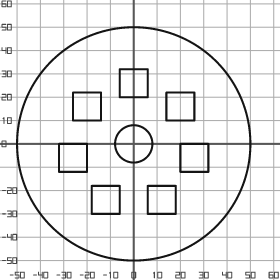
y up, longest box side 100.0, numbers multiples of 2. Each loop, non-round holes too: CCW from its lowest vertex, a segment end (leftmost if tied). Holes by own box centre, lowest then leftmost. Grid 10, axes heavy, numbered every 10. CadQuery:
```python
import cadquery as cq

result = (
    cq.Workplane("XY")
    .moveTo(0.0, 0.0)
    .circle(50.0)
    .moveTo(-18.0, -30.0)
    .lineTo(-6.0, -30.0)
    .lineTo(-6.0, -18.0)
    .lineTo(-18.0, -18.0)
    .close()
    .moveTo(6.0, -30.0)
    .lineTo(18.0, -30.0)
    .lineTo(18.0, -18.0)
    .lineTo(6.0, -18.0)
    .close()
    .moveTo(-32.0, -12.0)
    .lineTo(-20.0, -12.0)
    .lineTo(-20.0, 0.0)
    .lineTo(-32.0, 0.0)
    .close()
    .moveTo(20.0, -12.0)
    .lineTo(32.0, -12.0)
    .lineTo(32.0, 0.0)
    .lineTo(20.0, 0.0)
    .close()
    .moveTo(0.0, 0.0)
    .circle(8.0)
    .moveTo(-26.0, 10.0)
    .lineTo(-14.0, 10.0)
    .lineTo(-14.0, 22.0)
    .lineTo(-26.0, 22.0)
    .close()
    .moveTo(14.0, 10.0)
    .lineTo(26.0, 10.0)
    .lineTo(26.0, 22.0)
    .lineTo(14.0, 22.0)
    .close()
    .moveTo(-6.0, 20.0)
    .lineTo(6.0, 20.0)
    .lineTo(6.0, 32.0)
    .lineTo(-6.0, 32.0)
    .close()
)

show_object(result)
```